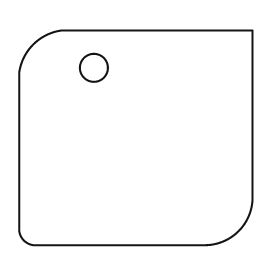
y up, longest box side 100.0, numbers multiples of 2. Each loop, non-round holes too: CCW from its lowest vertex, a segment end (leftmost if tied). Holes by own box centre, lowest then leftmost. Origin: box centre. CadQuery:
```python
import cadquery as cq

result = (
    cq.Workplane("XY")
    .moveTo(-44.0, -46.0)
    .lineTo(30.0, -46.0)
    .threePointArc((44.0, -40.0), (50.0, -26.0))
    .lineTo(50.0, 46.0)
    .lineTo(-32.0, 46.0)
    .threePointArc((-44.0, 40.0), (-50.0, 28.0))
    .lineTo(-50.0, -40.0)
    .threePointArc((-48.0, -44.0), (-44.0, -46.0))
    .close()
    .moveTo(-18.0, 30.0)
    .circle(6.0)
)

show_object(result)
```